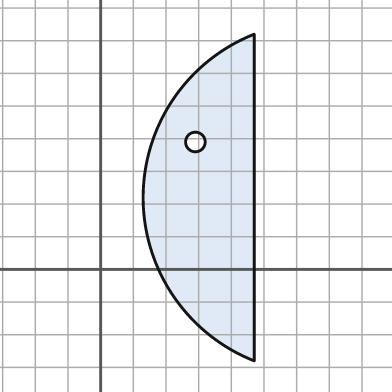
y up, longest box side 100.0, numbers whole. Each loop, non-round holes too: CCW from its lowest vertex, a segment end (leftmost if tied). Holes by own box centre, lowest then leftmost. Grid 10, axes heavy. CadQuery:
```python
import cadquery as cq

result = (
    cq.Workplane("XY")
    .moveTo(47.0, -28.0)
    .lineTo(47.0, 72.0)
    .threePointArc((13.0, 22.0), (47.0, -28.0))
    .close()
    .moveTo(29.0, 39.0)
    .circle(3.0)
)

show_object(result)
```